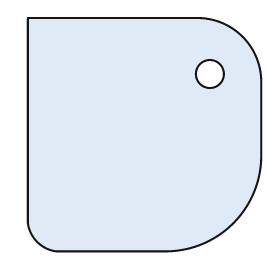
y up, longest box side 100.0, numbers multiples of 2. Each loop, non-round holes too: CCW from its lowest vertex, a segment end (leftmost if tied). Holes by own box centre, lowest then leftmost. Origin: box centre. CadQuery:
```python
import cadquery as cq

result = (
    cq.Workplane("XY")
    .moveTo(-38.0, -50.0)
    .lineTo(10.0, -50.0)
    .threePointArc((38.0, -38.0), (50.0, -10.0))
    .lineTo(50.0, 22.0)
    .threePointArc((42.0, 42.0), (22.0, 50.0))
    .lineTo(-50.0, 50.0)
    .lineTo(-50.0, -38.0)
    .threePointArc((-46.0, -46.0), (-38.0, -50.0))
    .close()
    .moveTo(28.0, 26.0)
    .circle(6.0)
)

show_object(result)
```